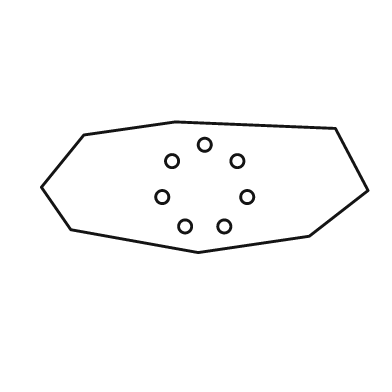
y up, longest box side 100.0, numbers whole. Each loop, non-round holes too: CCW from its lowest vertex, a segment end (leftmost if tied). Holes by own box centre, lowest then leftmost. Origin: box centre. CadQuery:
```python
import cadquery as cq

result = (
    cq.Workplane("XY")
    .moveTo(-2.0, -20.0)
    .lineTo(32.0, -15.0)
    .lineTo(50.0, -1.0)
    .lineTo(40.0, 18.0)
    .lineTo(-9.0, 20.0)
    .lineTo(-37.0, 16.0)
    .lineTo(-50.0, 0.0)
    .lineTo(-41.0, -13.0)
    .close()
    .moveTo(-6.0, -12.0)
    .circle(2.0)
    .moveTo(6.0, -12.0)
    .circle(2.0)
    .moveTo(-13.0, -3.0)
    .circle(2.0)
    .moveTo(13.0, -3.0)
    .circle(2.0)
    .moveTo(-10.0, 8.0)
    .circle(2.0)
    .moveTo(10.0, 8.0)
    .circle(2.0)
    .moveTo(0.0, 13.0)
    .circle(2.0)
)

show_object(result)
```